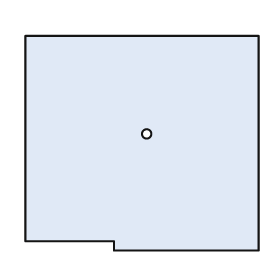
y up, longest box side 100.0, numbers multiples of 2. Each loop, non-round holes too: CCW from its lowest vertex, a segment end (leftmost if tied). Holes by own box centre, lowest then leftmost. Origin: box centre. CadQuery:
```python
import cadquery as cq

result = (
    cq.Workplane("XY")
    .moveTo(-12.0, -46.0)
    .lineTo(50.0, -46.0)
    .lineTo(50.0, 46.0)
    .lineTo(-50.0, 46.0)
    .lineTo(-50.0, -42.0)
    .lineTo(-12.0, -42.0)
    .close()
    .moveTo(2.0, 4.0)
    .circle(2.0)
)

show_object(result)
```